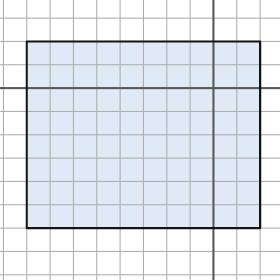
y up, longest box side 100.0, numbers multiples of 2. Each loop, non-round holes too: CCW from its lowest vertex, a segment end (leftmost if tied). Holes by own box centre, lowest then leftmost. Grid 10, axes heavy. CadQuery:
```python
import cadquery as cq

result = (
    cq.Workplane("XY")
    .moveTo(-80.0, -60.0)
    .lineTo(20.0, -60.0)
    .lineTo(20.0, 20.0)
    .lineTo(-80.0, 20.0)
    .close()
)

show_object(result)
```